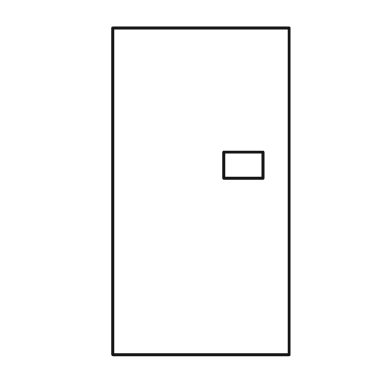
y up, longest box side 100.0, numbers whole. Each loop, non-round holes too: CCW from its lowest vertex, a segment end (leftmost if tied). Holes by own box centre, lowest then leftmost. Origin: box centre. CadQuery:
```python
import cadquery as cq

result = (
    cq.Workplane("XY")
    .moveTo(-27.0, -50.0)
    .lineTo(27.0, -50.0)
    .lineTo(27.0, 50.0)
    .lineTo(-27.0, 50.0)
    .close()
    .moveTo(7.0, 4.0)
    .lineTo(19.0, 4.0)
    .lineTo(19.0, 12.0)
    .lineTo(7.0, 12.0)
    .close()
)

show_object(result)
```